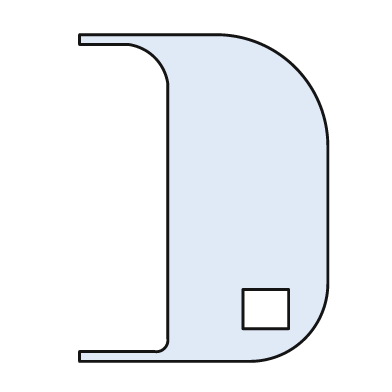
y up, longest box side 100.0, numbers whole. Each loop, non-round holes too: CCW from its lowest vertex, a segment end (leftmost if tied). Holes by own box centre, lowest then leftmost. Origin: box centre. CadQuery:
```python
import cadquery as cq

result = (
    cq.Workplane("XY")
    .moveTo(-38.0, -50.0)
    .lineTo(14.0, -50.0)
    .threePointArc((31.0, -43.0), (38.0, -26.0))
    .lineTo(38.0, 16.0)
    .threePointArc((28.0, 40.0), (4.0, 50.0))
    .lineTo(-38.0, 50.0)
    .lineTo(-38.0, 47.0)
    .lineTo(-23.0, 47.0)
    .threePointArc((-15.0, 43.0), (-11.0, 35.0))
    .lineTo(-11.0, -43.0)
    .threePointArc((-12.0, -46.0), (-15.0, -47.0))
    .lineTo(-38.0, -47.0)
    .close()
    .moveTo(12.0, -40.0)
    .lineTo(26.0, -40.0)
    .lineTo(26.0, -28.0)
    .lineTo(12.0, -28.0)
    .close()
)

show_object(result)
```